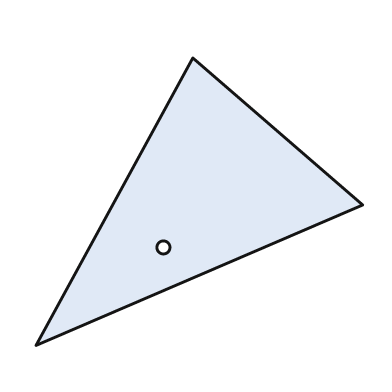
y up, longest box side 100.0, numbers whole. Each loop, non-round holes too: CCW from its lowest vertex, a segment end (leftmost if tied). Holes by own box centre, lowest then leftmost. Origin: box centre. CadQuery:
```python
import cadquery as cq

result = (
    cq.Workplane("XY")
    .moveTo(-50.0, -44.0)
    .lineTo(50.0, -1.0)
    .lineTo(-2.0, 44.0)
    .close()
    .moveTo(-11.0, -14.0)
    .circle(2.0)
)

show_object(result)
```